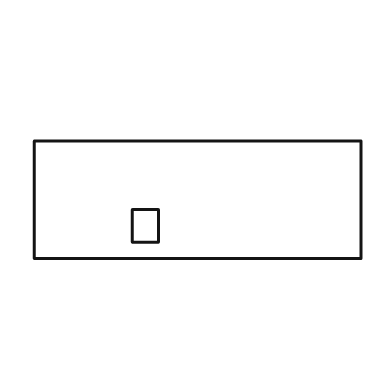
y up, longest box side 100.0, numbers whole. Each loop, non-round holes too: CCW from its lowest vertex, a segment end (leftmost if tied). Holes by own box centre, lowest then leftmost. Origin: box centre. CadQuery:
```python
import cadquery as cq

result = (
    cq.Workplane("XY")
    .moveTo(-50.0, -18.0)
    .lineTo(50.0, -18.0)
    .lineTo(50.0, 18.0)
    .lineTo(-50.0, 18.0)
    .close()
    .moveTo(-20.0, -13.0)
    .lineTo(-12.0, -13.0)
    .lineTo(-12.0, -3.0)
    .lineTo(-20.0, -3.0)
    .close()
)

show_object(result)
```